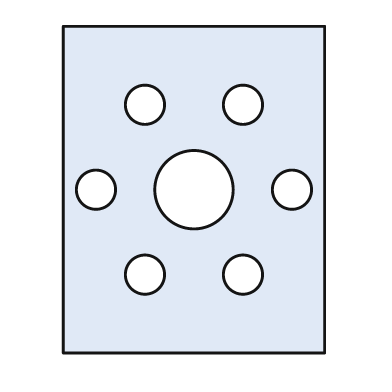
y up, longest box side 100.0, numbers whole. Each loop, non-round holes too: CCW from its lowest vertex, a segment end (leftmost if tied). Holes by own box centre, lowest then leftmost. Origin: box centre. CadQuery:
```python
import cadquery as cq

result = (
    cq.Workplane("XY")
    .moveTo(-40.0, -50.0)
    .lineTo(40.0, -50.0)
    .lineTo(40.0, 50.0)
    .lineTo(-40.0, 50.0)
    .close()
    .moveTo(-15.0, -26.0)
    .circle(6.0)
    .moveTo(15.0, -26.0)
    .circle(6.0)
    .moveTo(-30.0, 0.0)
    .circle(6.0)
    .moveTo(0.0, 0.0)
    .circle(12.0)
    .moveTo(30.0, 0.0)
    .circle(6.0)
    .moveTo(-15.0, 26.0)
    .circle(6.0)
    .moveTo(15.0, 26.0)
    .circle(6.0)
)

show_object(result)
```